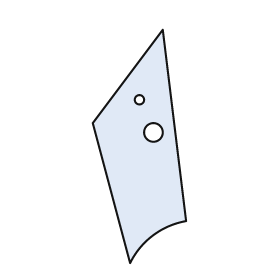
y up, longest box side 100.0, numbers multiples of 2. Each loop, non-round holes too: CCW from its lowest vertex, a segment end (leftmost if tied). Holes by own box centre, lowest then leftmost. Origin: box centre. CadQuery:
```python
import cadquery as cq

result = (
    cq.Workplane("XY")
    .moveTo(-4.0, -50.0)
    .threePointArc((6.0, -38.0), (20.0, -32.0))
    .lineTo(10.0, 50.0)
    .lineTo(-20.0, 10.0)
    .close()
    .moveTo(6.0, 6.0)
    .circle(4.0)
    .moveTo(0.0, 20.0)
    .circle(2.0)
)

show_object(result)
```